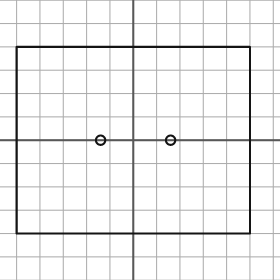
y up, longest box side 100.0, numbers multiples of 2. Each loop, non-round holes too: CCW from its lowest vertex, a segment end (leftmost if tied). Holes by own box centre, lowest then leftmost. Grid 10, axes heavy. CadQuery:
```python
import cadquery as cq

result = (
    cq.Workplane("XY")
    .moveTo(-50.0, -40.0)
    .lineTo(50.0, -40.0)
    .lineTo(50.0, 40.0)
    .lineTo(-50.0, 40.0)
    .close()
    .moveTo(-14.0, 0.0)
    .circle(2.0)
    .moveTo(16.0, 0.0)
    .circle(2.0)
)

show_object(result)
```